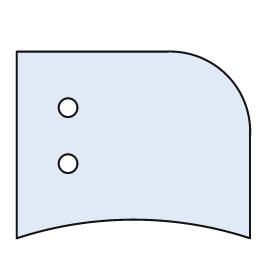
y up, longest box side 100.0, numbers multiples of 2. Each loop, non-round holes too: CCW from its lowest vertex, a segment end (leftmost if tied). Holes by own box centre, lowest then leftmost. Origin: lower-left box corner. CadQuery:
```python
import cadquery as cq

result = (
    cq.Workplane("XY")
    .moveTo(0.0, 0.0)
    .threePointArc((50.0, 8.0), (100.0, 0.0))
    .lineTo(100.0, 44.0)
    .threePointArc((90.0, 70.0), (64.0, 80.0))
    .lineTo(0.0, 80.0)
    .close()
    .moveTo(22.0, 32.0)
    .circle(4.0)
    .moveTo(22.0, 56.0)
    .circle(4.0)
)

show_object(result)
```